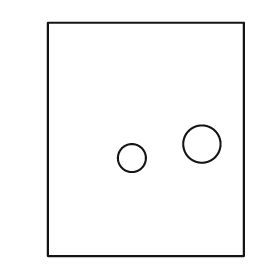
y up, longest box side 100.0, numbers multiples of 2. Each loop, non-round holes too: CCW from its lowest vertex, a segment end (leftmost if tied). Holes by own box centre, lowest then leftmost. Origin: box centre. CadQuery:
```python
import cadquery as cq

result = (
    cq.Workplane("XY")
    .moveTo(-42.0, -50.0)
    .lineTo(42.0, -50.0)
    .lineTo(42.0, 50.0)
    .lineTo(-42.0, 50.0)
    .close()
    .moveTo(-6.0, -8.0)
    .circle(6.0)
    .moveTo(24.0, -2.0)
    .circle(8.0)
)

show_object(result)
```